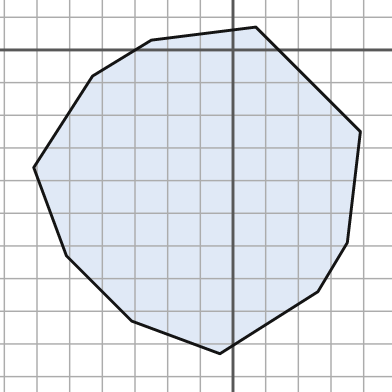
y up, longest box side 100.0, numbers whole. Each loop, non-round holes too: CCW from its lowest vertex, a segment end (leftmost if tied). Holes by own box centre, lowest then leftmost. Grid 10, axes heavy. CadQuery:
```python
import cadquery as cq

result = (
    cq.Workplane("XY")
    .moveTo(-4.0, -93.0)
    .lineTo(26.0, -74.0)
    .lineTo(35.0, -59.0)
    .lineTo(39.0, -25.0)
    .lineTo(7.0, 7.0)
    .lineTo(-25.0, 3.0)
    .lineTo(-43.0, -8.0)
    .lineTo(-61.0, -36.0)
    .lineTo(-51.0, -63.0)
    .lineTo(-31.0, -83.0)
    .close()
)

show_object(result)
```